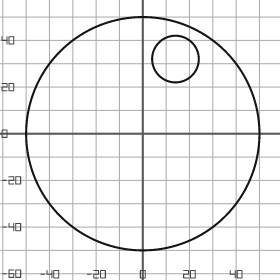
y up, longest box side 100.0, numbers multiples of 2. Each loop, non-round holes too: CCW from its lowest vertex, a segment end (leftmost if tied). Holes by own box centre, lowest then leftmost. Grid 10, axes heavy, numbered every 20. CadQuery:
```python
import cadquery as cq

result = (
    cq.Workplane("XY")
    .moveTo(0.0, 0.0)
    .circle(50.0)
    .moveTo(14.0, 32.0)
    .circle(10.0)
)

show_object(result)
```